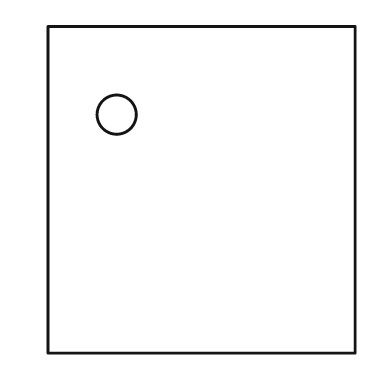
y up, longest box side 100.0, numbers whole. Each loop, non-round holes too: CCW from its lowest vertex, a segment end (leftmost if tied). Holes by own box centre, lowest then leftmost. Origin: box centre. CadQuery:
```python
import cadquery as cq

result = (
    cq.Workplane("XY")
    .moveTo(-47.0, -50.0)
    .lineTo(47.0, -50.0)
    .lineTo(47.0, 50.0)
    .lineTo(-47.0, 50.0)
    .close()
    .moveTo(-26.0, 23.0)
    .circle(6.0)
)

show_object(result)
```